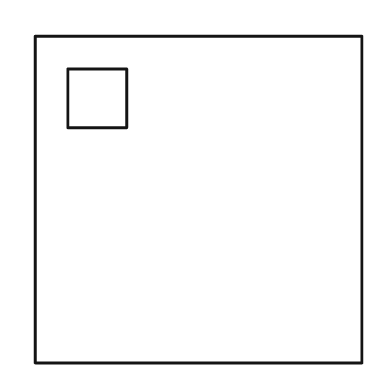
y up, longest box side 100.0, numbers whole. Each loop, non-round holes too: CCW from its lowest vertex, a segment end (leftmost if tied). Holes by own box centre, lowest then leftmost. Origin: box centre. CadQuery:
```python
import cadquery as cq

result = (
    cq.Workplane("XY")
    .moveTo(-50.0, -50.0)
    .lineTo(50.0, -50.0)
    .lineTo(50.0, 50.0)
    .lineTo(-50.0, 50.0)
    .close()
    .moveTo(-40.0, 22.0)
    .lineTo(-22.0, 22.0)
    .lineTo(-22.0, 40.0)
    .lineTo(-40.0, 40.0)
    .close()
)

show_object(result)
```